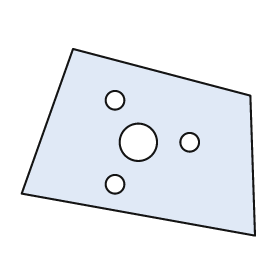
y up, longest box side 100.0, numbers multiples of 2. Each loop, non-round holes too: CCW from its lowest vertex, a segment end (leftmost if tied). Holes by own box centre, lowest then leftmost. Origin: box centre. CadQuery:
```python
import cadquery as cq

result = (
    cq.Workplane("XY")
    .moveTo(50.0, -40.0)
    .lineTo(48.0, 20.0)
    .lineTo(-28.0, 40.0)
    .lineTo(-50.0, -22.0)
    .close()
    .moveTo(-10.0, -18.0)
    .circle(4.0)
    .moveTo(0.0, 0.0)
    .circle(8.0)
    .moveTo(22.0, 0.0)
    .circle(4.0)
    .moveTo(-10.0, 18.0)
    .circle(4.0)
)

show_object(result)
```